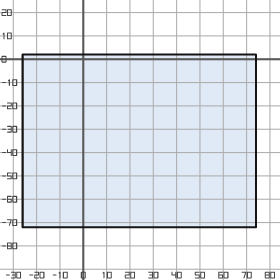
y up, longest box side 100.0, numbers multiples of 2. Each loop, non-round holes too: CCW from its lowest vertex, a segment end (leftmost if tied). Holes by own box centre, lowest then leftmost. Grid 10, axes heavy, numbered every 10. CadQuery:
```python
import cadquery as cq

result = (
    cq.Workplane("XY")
    .moveTo(-26.0, -72.0)
    .lineTo(74.0, -72.0)
    .lineTo(74.0, 2.0)
    .lineTo(-26.0, 2.0)
    .close()
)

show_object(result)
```